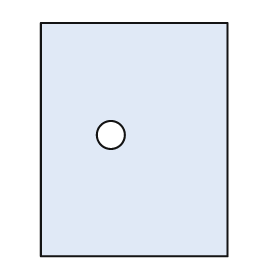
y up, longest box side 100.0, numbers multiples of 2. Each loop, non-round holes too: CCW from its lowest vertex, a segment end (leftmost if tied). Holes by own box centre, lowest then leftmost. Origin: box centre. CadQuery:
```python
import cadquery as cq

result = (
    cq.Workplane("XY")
    .moveTo(-40.0, -50.0)
    .lineTo(40.0, -50.0)
    .lineTo(40.0, 50.0)
    .lineTo(-40.0, 50.0)
    .close()
    .moveTo(-10.0, 2.0)
    .circle(6.0)
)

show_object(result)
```